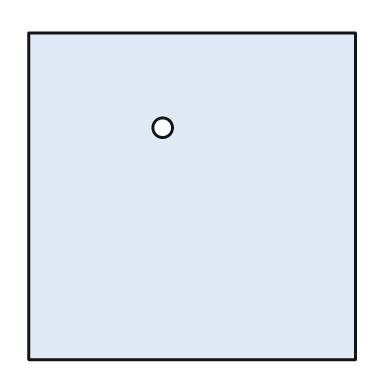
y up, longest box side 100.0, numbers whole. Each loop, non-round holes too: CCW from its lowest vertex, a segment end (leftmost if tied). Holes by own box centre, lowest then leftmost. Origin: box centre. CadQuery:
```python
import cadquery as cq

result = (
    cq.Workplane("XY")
    .moveTo(-50.0, -50.0)
    .lineTo(50.0, -50.0)
    .lineTo(50.0, 50.0)
    .lineTo(-50.0, 50.0)
    .close()
    .moveTo(-9.0, 21.0)
    .circle(3.0)
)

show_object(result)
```